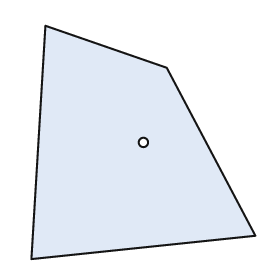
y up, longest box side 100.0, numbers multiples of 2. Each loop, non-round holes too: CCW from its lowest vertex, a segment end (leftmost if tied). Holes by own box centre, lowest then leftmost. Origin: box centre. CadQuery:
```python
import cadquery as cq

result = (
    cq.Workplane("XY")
    .moveTo(-48.0, -50.0)
    .lineTo(48.0, -40.0)
    .lineTo(10.0, 32.0)
    .lineTo(-42.0, 50.0)
    .close()
    .moveTo(0.0, 0.0)
    .circle(2.0)
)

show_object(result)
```